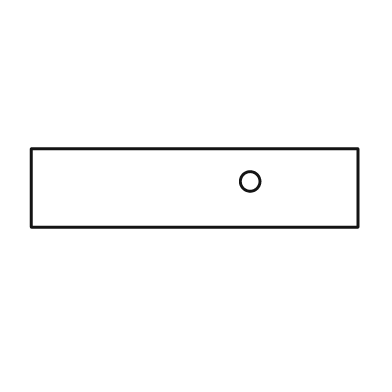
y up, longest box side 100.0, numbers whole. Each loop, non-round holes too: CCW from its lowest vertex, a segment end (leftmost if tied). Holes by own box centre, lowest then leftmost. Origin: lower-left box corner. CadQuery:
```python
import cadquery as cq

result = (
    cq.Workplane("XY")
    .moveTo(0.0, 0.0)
    .lineTo(100.0, 0.0)
    .lineTo(100.0, 24.0)
    .lineTo(0.0, 24.0)
    .close()
    .moveTo(67.0, 14.0)
    .circle(3.0)
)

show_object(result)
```